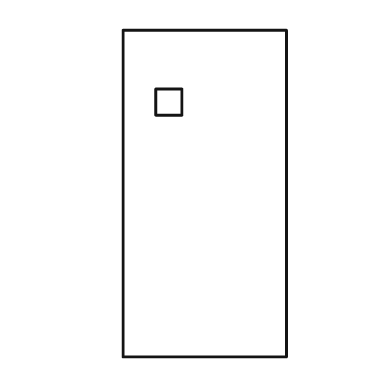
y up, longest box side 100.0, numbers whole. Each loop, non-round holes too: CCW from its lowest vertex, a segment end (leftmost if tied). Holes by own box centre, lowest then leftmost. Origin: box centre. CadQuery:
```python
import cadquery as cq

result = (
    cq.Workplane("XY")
    .moveTo(-25.0, -50.0)
    .lineTo(25.0, -50.0)
    .lineTo(25.0, 50.0)
    .lineTo(-25.0, 50.0)
    .close()
    .moveTo(-15.0, 24.0)
    .lineTo(-7.0, 24.0)
    .lineTo(-7.0, 32.0)
    .lineTo(-15.0, 32.0)
    .close()
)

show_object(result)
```